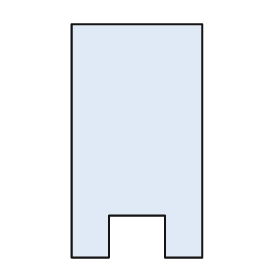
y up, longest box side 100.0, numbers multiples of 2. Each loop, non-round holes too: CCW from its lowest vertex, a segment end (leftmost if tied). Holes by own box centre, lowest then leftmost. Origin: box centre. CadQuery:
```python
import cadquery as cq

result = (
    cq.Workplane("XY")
    .moveTo(-28.0, -50.0)
    .lineTo(-12.0, -50.0)
    .lineTo(-12.0, -32.0)
    .lineTo(12.0, -32.0)
    .lineTo(12.0, -50.0)
    .lineTo(28.0, -50.0)
    .lineTo(28.0, 50.0)
    .lineTo(-28.0, 50.0)
    .close()
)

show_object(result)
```